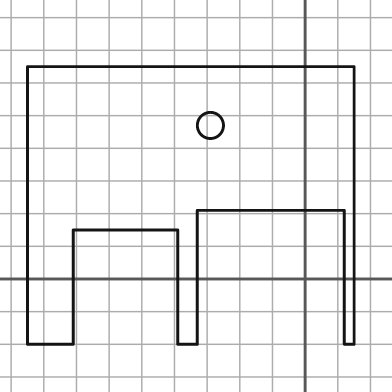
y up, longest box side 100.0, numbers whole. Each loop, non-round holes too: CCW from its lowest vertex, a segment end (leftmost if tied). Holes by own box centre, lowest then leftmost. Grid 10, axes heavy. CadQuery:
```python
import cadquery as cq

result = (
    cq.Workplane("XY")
    .moveTo(-85.0, -20.0)
    .lineTo(-71.0, -20.0)
    .lineTo(-71.0, 15.0)
    .lineTo(-39.0, 15.0)
    .lineTo(-39.0, -20.0)
    .lineTo(-33.0, -20.0)
    .lineTo(-33.0, 21.0)
    .lineTo(12.0, 21.0)
    .lineTo(12.0, -20.0)
    .lineTo(15.0, -20.0)
    .lineTo(15.0, 65.0)
    .lineTo(-85.0, 65.0)
    .close()
    .moveTo(-29.0, 47.0)
    .circle(4.0)
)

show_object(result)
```